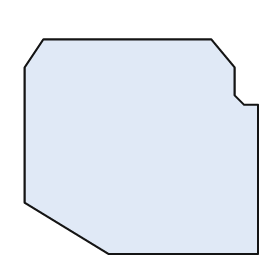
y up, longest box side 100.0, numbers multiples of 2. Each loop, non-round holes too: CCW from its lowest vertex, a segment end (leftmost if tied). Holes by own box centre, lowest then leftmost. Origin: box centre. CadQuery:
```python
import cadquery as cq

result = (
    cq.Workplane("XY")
    .moveTo(-14.0, -46.0)
    .lineTo(50.0, -46.0)
    .lineTo(50.0, 18.0)
    .lineTo(44.0, 18.0)
    .lineTo(40.0, 22.0)
    .lineTo(40.0, 34.0)
    .lineTo(30.0, 46.0)
    .lineTo(-42.0, 46.0)
    .lineTo(-50.0, 34.0)
    .lineTo(-50.0, -24.0)
    .close()
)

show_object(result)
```